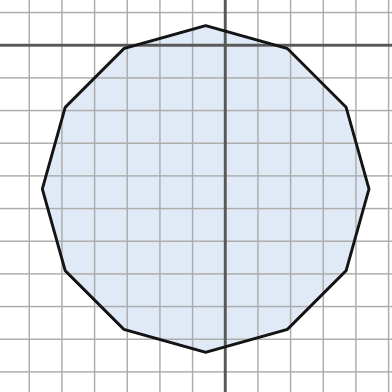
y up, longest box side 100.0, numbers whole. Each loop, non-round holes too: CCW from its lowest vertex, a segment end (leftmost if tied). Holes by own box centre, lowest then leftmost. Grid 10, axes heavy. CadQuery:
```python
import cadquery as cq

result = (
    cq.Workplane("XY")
    .moveTo(-6.0, -94.0)
    .lineTo(19.0, -87.0)
    .lineTo(37.0, -69.0)
    .lineTo(44.0, -44.0)
    .lineTo(37.0, -19.0)
    .lineTo(19.0, -1.0)
    .lineTo(-6.0, 6.0)
    .lineTo(-31.0, -1.0)
    .lineTo(-49.0, -19.0)
    .lineTo(-56.0, -44.0)
    .lineTo(-49.0, -69.0)
    .lineTo(-31.0, -87.0)
    .close()
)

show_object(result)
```